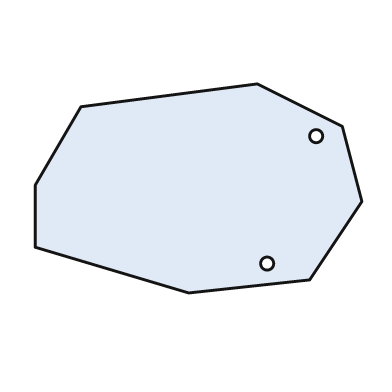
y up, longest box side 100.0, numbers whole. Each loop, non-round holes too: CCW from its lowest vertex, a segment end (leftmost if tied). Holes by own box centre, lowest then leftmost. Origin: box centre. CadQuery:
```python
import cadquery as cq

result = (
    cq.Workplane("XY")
    .moveTo(-3.0, -32.0)
    .lineTo(34.0, -28.0)
    .lineTo(50.0, -4.0)
    .lineTo(44.0, 19.0)
    .lineTo(18.0, 32.0)
    .lineTo(-36.0, 25.0)
    .lineTo(-50.0, 1.0)
    .lineTo(-50.0, -18.0)
    .close()
    .moveTo(21.0, -23.0)
    .circle(2.0)
    .moveTo(36.0, 16.0)
    .circle(2.0)
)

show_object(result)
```